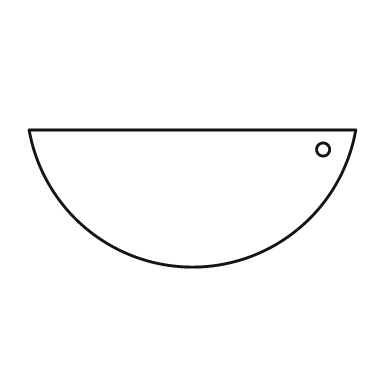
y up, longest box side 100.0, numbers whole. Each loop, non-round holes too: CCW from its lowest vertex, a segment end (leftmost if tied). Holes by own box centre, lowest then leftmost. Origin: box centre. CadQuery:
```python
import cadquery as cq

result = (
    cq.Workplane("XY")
    .moveTo(-50.0, 21.0)
    .threePointArc((0.0, -21.0), (50.0, 21.0))
    .close()
    .moveTo(40.0, 15.0)
    .circle(2.0)
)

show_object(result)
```